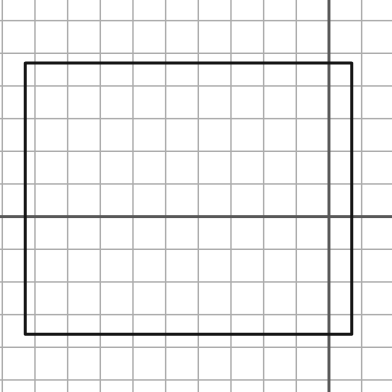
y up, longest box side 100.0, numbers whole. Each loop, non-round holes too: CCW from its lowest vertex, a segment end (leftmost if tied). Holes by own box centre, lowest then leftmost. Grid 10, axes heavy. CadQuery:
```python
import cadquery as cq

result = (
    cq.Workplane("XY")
    .moveTo(-93.0, -36.0)
    .lineTo(7.0, -36.0)
    .lineTo(7.0, 47.0)
    .lineTo(-93.0, 47.0)
    .close()
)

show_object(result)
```